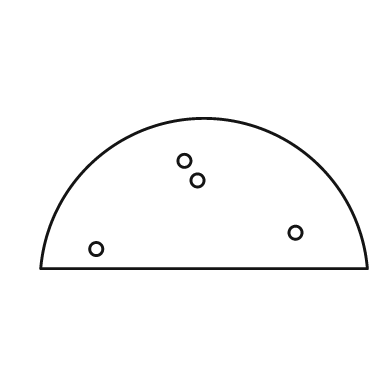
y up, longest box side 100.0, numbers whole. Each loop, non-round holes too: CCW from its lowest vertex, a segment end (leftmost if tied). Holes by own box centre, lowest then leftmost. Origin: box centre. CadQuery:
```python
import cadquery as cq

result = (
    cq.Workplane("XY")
    .moveTo(-50.0, -23.0)
    .lineTo(50.0, -23.0)
    .threePointArc((0.0, 23.0), (-50.0, -23.0))
    .close()
    .moveTo(-33.0, -17.0)
    .circle(2.0)
    .moveTo(28.0, -12.0)
    .circle(2.0)
    .moveTo(-2.0, 4.0)
    .circle(2.0)
    .moveTo(-6.0, 10.0)
    .circle(2.0)
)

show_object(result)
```